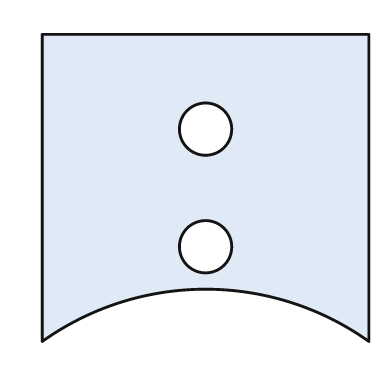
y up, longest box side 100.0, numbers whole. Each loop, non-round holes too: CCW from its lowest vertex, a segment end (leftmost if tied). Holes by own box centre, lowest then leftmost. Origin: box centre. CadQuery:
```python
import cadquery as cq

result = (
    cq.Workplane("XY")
    .moveTo(-50.0, -47.0)
    .threePointArc((0.0, -31.0), (50.0, -47.0))
    .lineTo(50.0, 47.0)
    .lineTo(-50.0, 47.0)
    .close()
    .moveTo(0.0, -18.0)
    .circle(8.0)
    .moveTo(0.0, 18.0)
    .circle(8.0)
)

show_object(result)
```